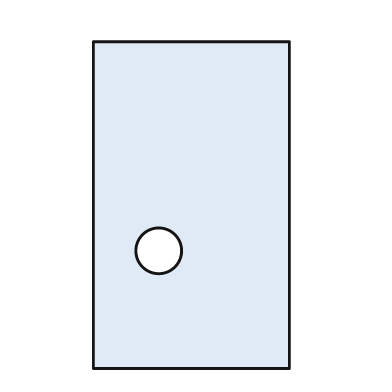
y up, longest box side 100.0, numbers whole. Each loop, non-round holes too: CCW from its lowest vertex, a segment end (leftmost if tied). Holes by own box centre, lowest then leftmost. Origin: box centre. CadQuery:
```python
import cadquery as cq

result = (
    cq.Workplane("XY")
    .moveTo(-30.0, -50.0)
    .lineTo(30.0, -50.0)
    .lineTo(30.0, 50.0)
    .lineTo(-30.0, 50.0)
    .close()
    .moveTo(-10.0, -14.0)
    .circle(7.0)
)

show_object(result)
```